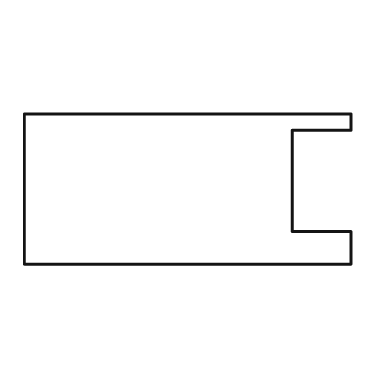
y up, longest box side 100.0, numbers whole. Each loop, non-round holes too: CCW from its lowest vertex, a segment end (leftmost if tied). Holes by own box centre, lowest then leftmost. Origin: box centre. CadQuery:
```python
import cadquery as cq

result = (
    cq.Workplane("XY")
    .moveTo(-50.0, -23.0)
    .lineTo(50.0, -23.0)
    .lineTo(50.0, -13.0)
    .lineTo(32.0, -13.0)
    .lineTo(32.0, 18.0)
    .lineTo(50.0, 18.0)
    .lineTo(50.0, 23.0)
    .lineTo(-50.0, 23.0)
    .close()
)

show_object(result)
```